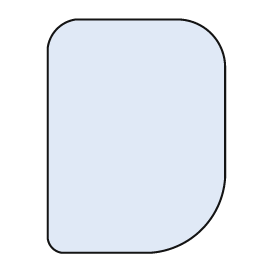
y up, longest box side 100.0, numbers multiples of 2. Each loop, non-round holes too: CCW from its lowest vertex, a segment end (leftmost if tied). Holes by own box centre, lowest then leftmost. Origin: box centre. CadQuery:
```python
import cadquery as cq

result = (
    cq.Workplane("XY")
    .moveTo(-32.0, -50.0)
    .lineTo(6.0, -50.0)
    .threePointArc((28.0, -40.0), (38.0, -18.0))
    .lineTo(38.0, 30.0)
    .threePointArc((32.0, 44.0), (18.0, 50.0))
    .lineTo(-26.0, 50.0)
    .threePointArc((-34.0, 46.0), (-38.0, 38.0))
    .lineTo(-38.0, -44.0)
    .threePointArc((-36.0, -48.0), (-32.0, -50.0))
    .close()
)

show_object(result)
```